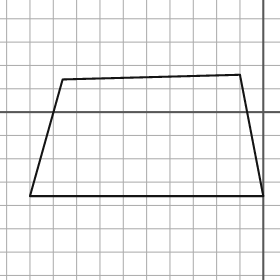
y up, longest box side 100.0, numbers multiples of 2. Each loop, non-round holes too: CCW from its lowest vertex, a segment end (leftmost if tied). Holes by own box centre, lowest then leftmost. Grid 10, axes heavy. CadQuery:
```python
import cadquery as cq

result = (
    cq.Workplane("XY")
    .moveTo(-100.0, -36.0)
    .lineTo(0.0, -36.0)
    .lineTo(-10.0, 16.0)
    .lineTo(-86.0, 14.0)
    .close()
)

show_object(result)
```